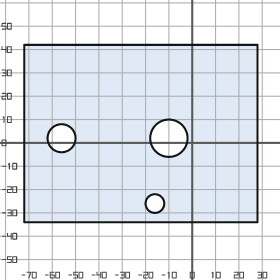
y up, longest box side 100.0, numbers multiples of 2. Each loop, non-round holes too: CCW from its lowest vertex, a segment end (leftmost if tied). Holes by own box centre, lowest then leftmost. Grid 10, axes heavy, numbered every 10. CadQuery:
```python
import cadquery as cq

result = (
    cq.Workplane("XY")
    .moveTo(-72.0, -34.0)
    .lineTo(28.0, -34.0)
    .lineTo(28.0, 42.0)
    .lineTo(-72.0, 42.0)
    .close()
    .moveTo(-16.0, -26.0)
    .circle(4.0)
    .moveTo(-56.0, 2.0)
    .circle(6.0)
    .moveTo(-10.0, 2.0)
    .circle(8.0)
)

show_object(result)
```